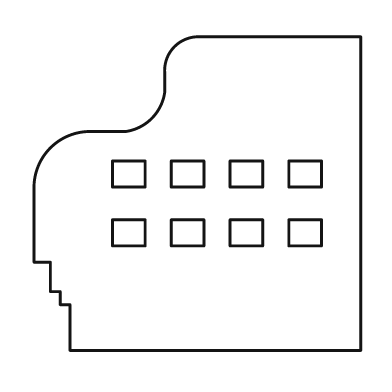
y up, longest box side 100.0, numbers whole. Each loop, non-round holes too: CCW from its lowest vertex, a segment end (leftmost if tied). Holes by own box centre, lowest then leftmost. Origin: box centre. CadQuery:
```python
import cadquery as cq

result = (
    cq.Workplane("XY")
    .moveTo(-39.0, -48.0)
    .lineTo(50.0, -48.0)
    .lineTo(50.0, 48.0)
    .lineTo(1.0, 48.0)
    .threePointArc((-7.0, 45.0), (-10.0, 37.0))
    .lineTo(-10.0, 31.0)
    .threePointArc((-14.0, 23.0), (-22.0, 19.0))
    .lineTo(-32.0, 19.0)
    .threePointArc((-45.0, 14.0), (-50.0, 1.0))
    .lineTo(-50.0, -21.0)
    .lineTo(-45.0, -21.0)
    .lineTo(-45.0, -30.0)
    .lineTo(-42.0, -30.0)
    .lineTo(-42.0, -34.0)
    .lineTo(-39.0, -34.0)
    .close()
    .moveTo(-26.0, -16.0)
    .lineTo(-16.0, -16.0)
    .lineTo(-16.0, -8.0)
    .lineTo(-26.0, -8.0)
    .close()
    .moveTo(-8.0, -16.0)
    .lineTo(2.0, -16.0)
    .lineTo(2.0, -8.0)
    .lineTo(-8.0, -8.0)
    .close()
    .moveTo(10.0, -16.0)
    .lineTo(20.0, -16.0)
    .lineTo(20.0, -8.0)
    .lineTo(10.0, -8.0)
    .close()
    .moveTo(28.0, -16.0)
    .lineTo(38.0, -16.0)
    .lineTo(38.0, -8.0)
    .lineTo(28.0, -8.0)
    .close()
    .moveTo(-26.0, 2.0)
    .lineTo(-16.0, 2.0)
    .lineTo(-16.0, 10.0)
    .lineTo(-26.0, 10.0)
    .close()
    .moveTo(-8.0, 2.0)
    .lineTo(2.0, 2.0)
    .lineTo(2.0, 10.0)
    .lineTo(-8.0, 10.0)
    .close()
    .moveTo(10.0, 2.0)
    .lineTo(20.0, 2.0)
    .lineTo(20.0, 10.0)
    .lineTo(10.0, 10.0)
    .close()
    .moveTo(28.0, 2.0)
    .lineTo(38.0, 2.0)
    .lineTo(38.0, 10.0)
    .lineTo(28.0, 10.0)
    .close()
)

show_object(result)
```